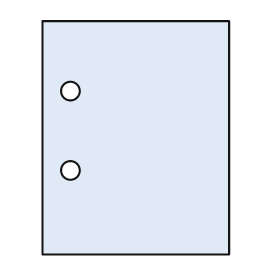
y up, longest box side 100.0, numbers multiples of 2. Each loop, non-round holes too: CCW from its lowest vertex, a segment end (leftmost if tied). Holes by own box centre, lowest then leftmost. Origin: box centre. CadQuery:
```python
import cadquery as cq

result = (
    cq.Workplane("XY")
    .moveTo(-40.0, -50.0)
    .lineTo(40.0, -50.0)
    .lineTo(40.0, 50.0)
    .lineTo(-40.0, 50.0)
    .close()
    .moveTo(-28.0, -14.0)
    .circle(4.0)
    .moveTo(-28.0, 20.0)
    .circle(4.0)
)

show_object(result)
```